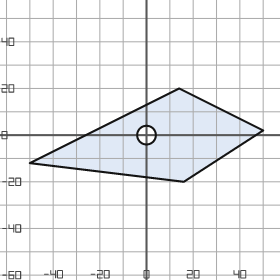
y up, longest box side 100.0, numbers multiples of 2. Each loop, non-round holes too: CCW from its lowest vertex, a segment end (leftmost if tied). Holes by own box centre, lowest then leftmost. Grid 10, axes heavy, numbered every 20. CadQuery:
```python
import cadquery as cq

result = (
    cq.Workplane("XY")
    .moveTo(16.0, -20.0)
    .lineTo(50.0, 2.0)
    .lineTo(14.0, 20.0)
    .lineTo(-50.0, -12.0)
    .close()
    .moveTo(0.0, 0.0)
    .circle(4.0)
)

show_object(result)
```